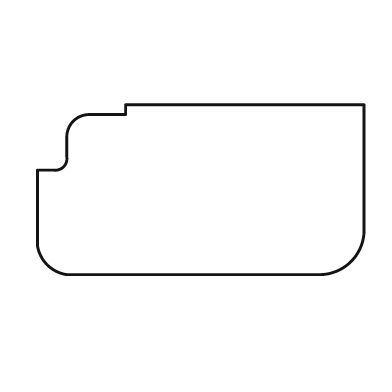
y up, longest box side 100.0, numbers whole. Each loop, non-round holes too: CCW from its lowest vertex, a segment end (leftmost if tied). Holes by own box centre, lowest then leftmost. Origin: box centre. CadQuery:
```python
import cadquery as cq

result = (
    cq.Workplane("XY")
    .moveTo(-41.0, -26.0)
    .lineTo(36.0, -26.0)
    .threePointArc((46.0, -22.0), (50.0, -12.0))
    .lineTo(50.0, 26.0)
    .lineTo(-23.0, 26.0)
    .lineTo(-23.0, 23.0)
    .lineTo(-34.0, 23.0)
    .threePointArc((-39.0, 21.0), (-41.0, 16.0))
    .lineTo(-41.0, 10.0)
    .threePointArc((-42.0, 7.0), (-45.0, 6.0))
    .lineTo(-50.0, 6.0)
    .lineTo(-50.0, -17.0)
    .threePointArc((-47.0, -23.0), (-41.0, -26.0))
    .close()
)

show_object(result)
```